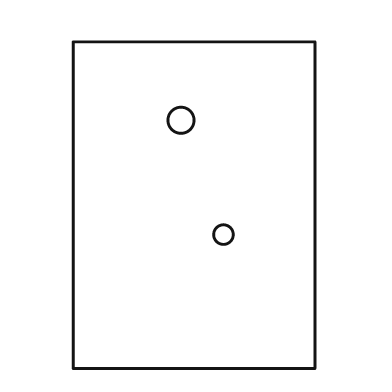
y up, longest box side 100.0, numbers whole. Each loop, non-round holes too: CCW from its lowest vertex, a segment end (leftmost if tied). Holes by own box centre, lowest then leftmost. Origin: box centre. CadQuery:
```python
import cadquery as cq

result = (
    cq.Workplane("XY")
    .moveTo(-37.0, -50.0)
    .lineTo(37.0, -50.0)
    .lineTo(37.0, 50.0)
    .lineTo(-37.0, 50.0)
    .close()
    .moveTo(9.0, -9.0)
    .circle(3.0)
    .moveTo(-4.0, 26.0)
    .circle(4.0)
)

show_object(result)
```